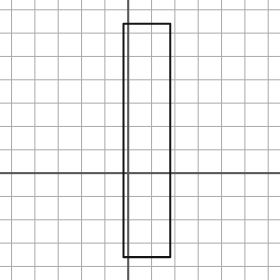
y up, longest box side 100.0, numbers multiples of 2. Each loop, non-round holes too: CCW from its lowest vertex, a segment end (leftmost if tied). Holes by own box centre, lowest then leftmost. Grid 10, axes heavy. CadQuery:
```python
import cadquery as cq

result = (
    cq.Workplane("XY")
    .moveTo(-2.0, -36.0)
    .lineTo(18.0, -36.0)
    .lineTo(18.0, 64.0)
    .lineTo(-2.0, 64.0)
    .close()
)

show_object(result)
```